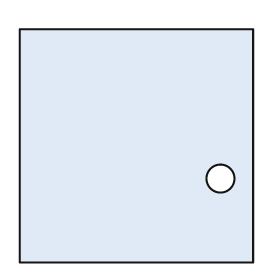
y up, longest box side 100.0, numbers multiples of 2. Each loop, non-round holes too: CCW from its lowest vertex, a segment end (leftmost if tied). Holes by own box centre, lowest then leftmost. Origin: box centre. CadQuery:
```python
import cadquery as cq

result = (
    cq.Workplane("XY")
    .moveTo(-50.0, -50.0)
    .lineTo(50.0, -50.0)
    .lineTo(50.0, 50.0)
    .lineTo(-50.0, 50.0)
    .close()
    .moveTo(36.0, -14.0)
    .circle(6.0)
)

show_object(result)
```